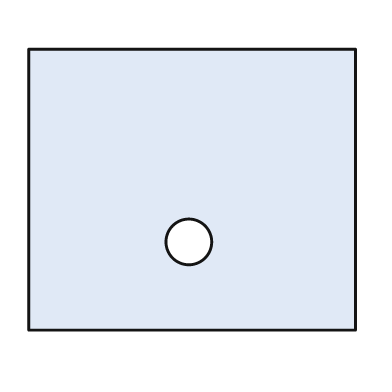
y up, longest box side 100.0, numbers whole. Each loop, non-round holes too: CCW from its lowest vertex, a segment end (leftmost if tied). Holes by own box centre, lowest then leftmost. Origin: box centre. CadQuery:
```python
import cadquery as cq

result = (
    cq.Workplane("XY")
    .moveTo(-50.0, -43.0)
    .lineTo(50.0, -43.0)
    .lineTo(50.0, 43.0)
    .lineTo(-50.0, 43.0)
    .close()
    .moveTo(-1.0, -16.0)
    .circle(7.0)
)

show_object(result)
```